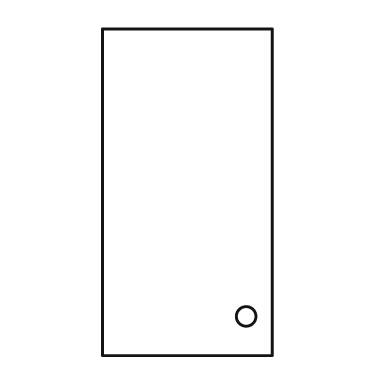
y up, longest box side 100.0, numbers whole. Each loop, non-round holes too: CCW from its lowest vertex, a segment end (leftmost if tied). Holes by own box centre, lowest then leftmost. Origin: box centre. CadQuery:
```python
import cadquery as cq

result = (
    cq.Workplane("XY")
    .moveTo(-26.0, -50.0)
    .lineTo(26.0, -50.0)
    .lineTo(26.0, 50.0)
    .lineTo(-26.0, 50.0)
    .close()
    .moveTo(18.0, -38.0)
    .circle(3.0)
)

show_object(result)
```